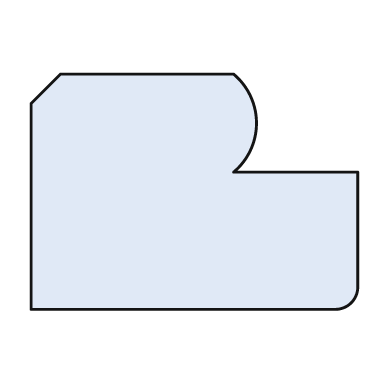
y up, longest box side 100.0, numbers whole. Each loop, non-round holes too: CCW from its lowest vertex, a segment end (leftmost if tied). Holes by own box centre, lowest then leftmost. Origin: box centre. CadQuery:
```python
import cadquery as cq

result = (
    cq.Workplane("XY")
    .moveTo(-50.0, -36.0)
    .lineTo(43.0, -36.0)
    .threePointArc((48.0, -34.0), (50.0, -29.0))
    .lineTo(50.0, 6.0)
    .lineTo(12.0, 6.0)
    .threePointArc((19.0, 21.0), (12.0, 36.0))
    .lineTo(-41.0, 36.0)
    .lineTo(-50.0, 27.0)
    .close()
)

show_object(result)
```